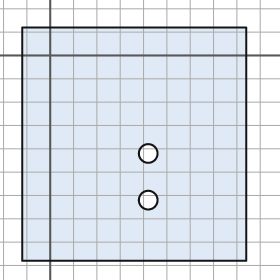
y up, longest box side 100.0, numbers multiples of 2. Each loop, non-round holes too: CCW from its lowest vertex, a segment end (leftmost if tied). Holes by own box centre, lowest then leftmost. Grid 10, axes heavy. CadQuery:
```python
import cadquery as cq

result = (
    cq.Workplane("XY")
    .moveTo(-12.0, -88.0)
    .lineTo(84.0, -88.0)
    .lineTo(84.0, 12.0)
    .lineTo(-12.0, 12.0)
    .close()
    .moveTo(42.0, -62.0)
    .circle(4.0)
    .moveTo(42.0, -42.0)
    .circle(4.0)
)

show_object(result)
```